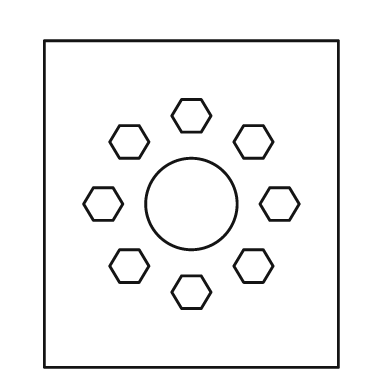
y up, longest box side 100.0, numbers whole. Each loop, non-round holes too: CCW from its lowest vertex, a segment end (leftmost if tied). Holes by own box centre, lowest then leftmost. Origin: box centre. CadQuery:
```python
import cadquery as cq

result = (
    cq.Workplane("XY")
    .moveTo(-45.0, -50.0)
    .lineTo(45.0, -50.0)
    .lineTo(45.0, 50.0)
    .lineTo(-45.0, 50.0)
    .close()
    .moveTo(-3.0, -32.0)
    .lineTo(3.0, -32.0)
    .lineTo(6.0, -27.0)
    .lineTo(3.0, -22.0)
    .lineTo(-3.0, -22.0)
    .lineTo(-6.0, -27.0)
    .close()
    .moveTo(-22.0, -24.0)
    .lineTo(-16.0, -24.0)
    .lineTo(-13.0, -19.0)
    .lineTo(-16.0, -14.0)
    .lineTo(-22.0, -14.0)
    .lineTo(-25.0, -19.0)
    .close()
    .moveTo(16.0, -24.0)
    .lineTo(22.0, -24.0)
    .lineTo(25.0, -19.0)
    .lineTo(22.0, -14.0)
    .lineTo(16.0, -14.0)
    .lineTo(13.0, -19.0)
    .close()
    .moveTo(-30.0, -5.0)
    .lineTo(-24.0, -5.0)
    .lineTo(-21.0, 0.0)
    .lineTo(-24.0, 5.0)
    .lineTo(-30.0, 5.0)
    .lineTo(-33.0, 0.0)
    .close()
    .moveTo(0.0, 0.0)
    .circle(14.0)
    .moveTo(24.0, -5.0)
    .lineTo(30.0, -5.0)
    .lineTo(33.0, 0.0)
    .lineTo(30.0, 5.0)
    .lineTo(24.0, 5.0)
    .lineTo(21.0, 0.0)
    .close()
    .moveTo(-22.0, 14.0)
    .lineTo(-16.0, 14.0)
    .lineTo(-13.0, 19.0)
    .lineTo(-16.0, 24.0)
    .lineTo(-22.0, 24.0)
    .lineTo(-25.0, 19.0)
    .close()
    .moveTo(16.0, 14.0)
    .lineTo(22.0, 14.0)
    .lineTo(25.0, 19.0)
    .lineTo(22.0, 24.0)
    .lineTo(16.0, 24.0)
    .lineTo(13.0, 19.0)
    .close()
    .moveTo(-3.0, 22.0)
    .lineTo(3.0, 22.0)
    .lineTo(6.0, 27.0)
    .lineTo(3.0, 32.0)
    .lineTo(-3.0, 32.0)
    .lineTo(-6.0, 27.0)
    .close()
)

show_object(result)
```